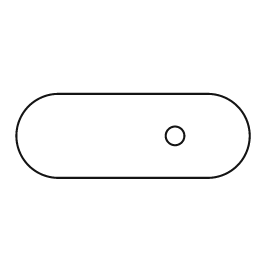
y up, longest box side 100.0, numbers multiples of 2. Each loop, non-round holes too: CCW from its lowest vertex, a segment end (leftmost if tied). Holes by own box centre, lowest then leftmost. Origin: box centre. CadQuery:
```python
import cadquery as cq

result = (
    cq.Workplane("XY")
    .moveTo(-32.0, -18.0)
    .lineTo(32.0, -18.0)
    .threePointArc((50.0, 0.0), (32.0, 18.0))
    .lineTo(-32.0, 18.0)
    .threePointArc((-50.0, 0.0), (-32.0, -18.0))
    .close()
    .moveTo(18.0, 0.0)
    .circle(4.0)
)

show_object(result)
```